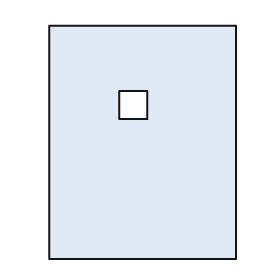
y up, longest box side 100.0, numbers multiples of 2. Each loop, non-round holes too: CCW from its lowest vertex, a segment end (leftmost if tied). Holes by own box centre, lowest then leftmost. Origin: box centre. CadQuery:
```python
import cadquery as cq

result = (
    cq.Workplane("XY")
    .moveTo(-40.0, -50.0)
    .lineTo(40.0, -50.0)
    .lineTo(40.0, 50.0)
    .lineTo(-40.0, 50.0)
    .close()
    .moveTo(-10.0, 10.0)
    .lineTo(2.0, 10.0)
    .lineTo(2.0, 22.0)
    .lineTo(-10.0, 22.0)
    .close()
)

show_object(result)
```